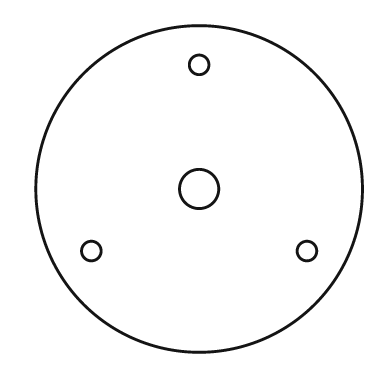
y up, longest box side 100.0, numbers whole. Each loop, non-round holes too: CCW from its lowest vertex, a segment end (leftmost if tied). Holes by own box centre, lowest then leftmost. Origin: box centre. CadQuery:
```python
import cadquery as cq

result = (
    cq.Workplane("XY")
    .moveTo(0.0, 0.0)
    .circle(50.0)
    .moveTo(-33.0, -19.0)
    .circle(3.0)
    .moveTo(33.0, -19.0)
    .circle(3.0)
    .moveTo(0.0, 0.0)
    .circle(6.0)
    .moveTo(0.0, 38.0)
    .circle(3.0)
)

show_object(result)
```